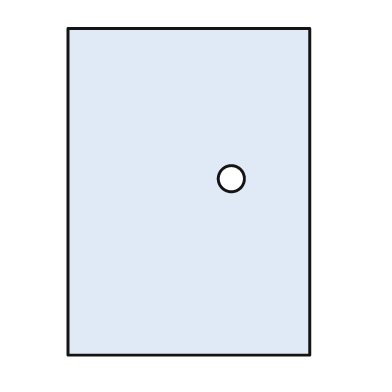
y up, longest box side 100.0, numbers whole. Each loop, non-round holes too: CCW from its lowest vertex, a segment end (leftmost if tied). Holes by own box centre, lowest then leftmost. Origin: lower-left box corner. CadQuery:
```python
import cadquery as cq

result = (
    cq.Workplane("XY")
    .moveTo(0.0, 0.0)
    .lineTo(74.0, 0.0)
    .lineTo(74.0, 100.0)
    .lineTo(0.0, 100.0)
    .close()
    .moveTo(50.0, 54.0)
    .circle(4.0)
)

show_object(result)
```